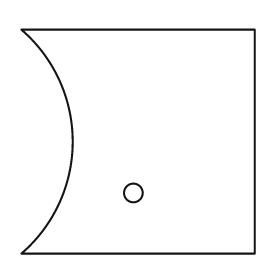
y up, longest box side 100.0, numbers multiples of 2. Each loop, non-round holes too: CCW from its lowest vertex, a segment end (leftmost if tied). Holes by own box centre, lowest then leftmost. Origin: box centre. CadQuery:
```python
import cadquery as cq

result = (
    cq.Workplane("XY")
    .moveTo(-50.0, -48.0)
    .lineTo(50.0, -48.0)
    .lineTo(50.0, 48.0)
    .lineTo(-50.0, 48.0)
    .threePointArc((-28.0, 0.0), (-50.0, -48.0))
    .close()
    .moveTo(-2.0, -22.0)
    .circle(4.0)
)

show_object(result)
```